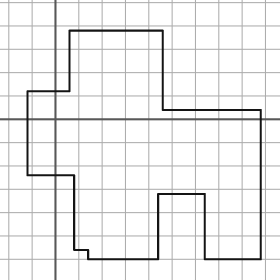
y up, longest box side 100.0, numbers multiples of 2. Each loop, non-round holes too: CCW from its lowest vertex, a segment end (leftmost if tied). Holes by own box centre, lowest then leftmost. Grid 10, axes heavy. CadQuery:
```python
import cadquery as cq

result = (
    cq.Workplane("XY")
    .moveTo(14.0, -60.0)
    .lineTo(44.0, -60.0)
    .lineTo(44.0, -32.0)
    .lineTo(64.0, -32.0)
    .lineTo(64.0, -60.0)
    .lineTo(88.0, -60.0)
    .lineTo(88.0, 4.0)
    .lineTo(46.0, 4.0)
    .lineTo(46.0, 38.0)
    .lineTo(6.0, 38.0)
    .lineTo(6.0, 12.0)
    .lineTo(-12.0, 12.0)
    .lineTo(-12.0, -24.0)
    .lineTo(8.0, -24.0)
    .lineTo(8.0, -56.0)
    .lineTo(14.0, -56.0)
    .close()
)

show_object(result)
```